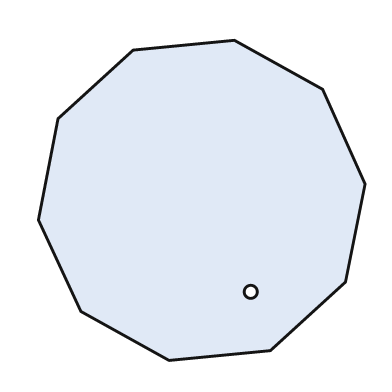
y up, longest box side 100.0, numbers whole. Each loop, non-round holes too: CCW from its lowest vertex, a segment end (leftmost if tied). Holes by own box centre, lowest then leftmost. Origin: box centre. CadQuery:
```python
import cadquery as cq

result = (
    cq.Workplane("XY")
    .moveTo(-10.0, -49.0)
    .lineTo(21.0, -46.0)
    .lineTo(44.0, -25.0)
    .lineTo(50.0, 5.0)
    .lineTo(37.0, 34.0)
    .lineTo(10.0, 49.0)
    .lineTo(-21.0, 46.0)
    .lineTo(-44.0, 25.0)
    .lineTo(-50.0, -6.0)
    .lineTo(-37.0, -34.0)
    .close()
    .moveTo(15.0, -28.0)
    .circle(2.0)
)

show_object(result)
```